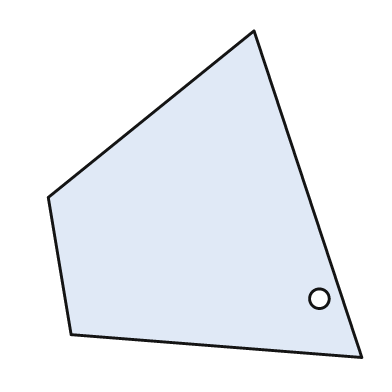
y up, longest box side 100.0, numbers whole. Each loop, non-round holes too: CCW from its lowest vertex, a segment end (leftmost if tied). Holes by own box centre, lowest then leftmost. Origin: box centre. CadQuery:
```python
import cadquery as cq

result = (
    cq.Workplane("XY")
    .moveTo(48.0, -50.0)
    .lineTo(15.0, 50.0)
    .lineTo(-48.0, -1.0)
    .lineTo(-41.0, -43.0)
    .close()
    .moveTo(35.0, -32.0)
    .circle(3.0)
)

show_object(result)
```